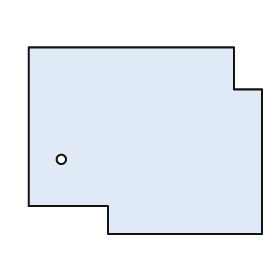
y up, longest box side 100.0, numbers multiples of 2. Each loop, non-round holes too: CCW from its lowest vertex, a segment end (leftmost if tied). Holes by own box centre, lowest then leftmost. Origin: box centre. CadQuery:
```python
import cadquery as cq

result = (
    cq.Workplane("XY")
    .moveTo(-16.0, -40.0)
    .lineTo(50.0, -40.0)
    .lineTo(50.0, 22.0)
    .lineTo(38.0, 22.0)
    .lineTo(38.0, 40.0)
    .lineTo(-50.0, 40.0)
    .lineTo(-50.0, -28.0)
    .lineTo(-16.0, -28.0)
    .close()
    .moveTo(-36.0, -8.0)
    .circle(2.0)
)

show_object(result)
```